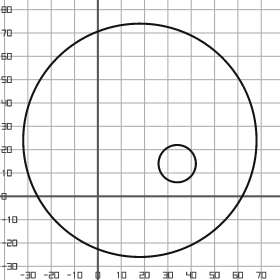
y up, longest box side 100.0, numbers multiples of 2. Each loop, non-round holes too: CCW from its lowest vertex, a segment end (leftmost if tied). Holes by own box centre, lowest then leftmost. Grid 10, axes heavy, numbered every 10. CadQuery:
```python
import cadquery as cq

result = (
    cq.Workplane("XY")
    .moveTo(18.0, 24.0)
    .circle(50.0)
    .moveTo(34.0, 14.0)
    .circle(8.0)
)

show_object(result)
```